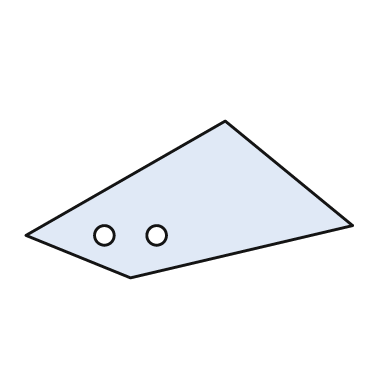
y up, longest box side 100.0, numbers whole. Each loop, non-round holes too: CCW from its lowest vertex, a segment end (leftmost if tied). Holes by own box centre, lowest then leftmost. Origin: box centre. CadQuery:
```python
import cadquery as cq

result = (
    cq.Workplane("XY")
    .moveTo(-18.0, -24.0)
    .lineTo(50.0, -8.0)
    .lineTo(11.0, 24.0)
    .lineTo(-50.0, -11.0)
    .close()
    .moveTo(-26.0, -11.0)
    .circle(3.0)
    .moveTo(-10.0, -11.0)
    .circle(3.0)
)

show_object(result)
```